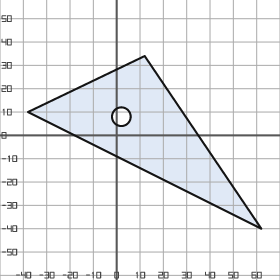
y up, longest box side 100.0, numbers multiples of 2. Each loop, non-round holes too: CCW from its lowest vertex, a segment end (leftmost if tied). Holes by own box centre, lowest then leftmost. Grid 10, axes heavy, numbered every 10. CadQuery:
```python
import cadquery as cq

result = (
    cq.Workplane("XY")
    .moveTo(62.0, -40.0)
    .lineTo(12.0, 34.0)
    .lineTo(-38.0, 10.0)
    .close()
    .moveTo(2.0, 8.0)
    .circle(4.0)
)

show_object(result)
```